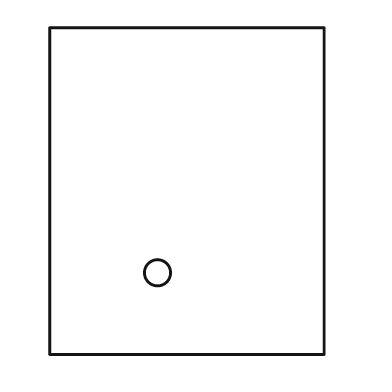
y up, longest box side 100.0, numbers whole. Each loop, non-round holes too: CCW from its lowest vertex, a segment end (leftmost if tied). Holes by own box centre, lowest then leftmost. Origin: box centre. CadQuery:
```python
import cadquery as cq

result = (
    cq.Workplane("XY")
    .moveTo(-42.0, -50.0)
    .lineTo(42.0, -50.0)
    .lineTo(42.0, 50.0)
    .lineTo(-42.0, 50.0)
    .close()
    .moveTo(-9.0, -25.0)
    .circle(4.0)
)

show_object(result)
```